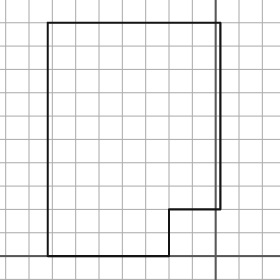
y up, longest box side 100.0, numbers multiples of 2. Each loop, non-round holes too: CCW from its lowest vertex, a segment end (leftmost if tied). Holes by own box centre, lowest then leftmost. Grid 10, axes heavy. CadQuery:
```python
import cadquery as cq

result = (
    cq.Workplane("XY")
    .moveTo(-72.0, 0.0)
    .lineTo(-20.0, 0.0)
    .lineTo(-20.0, 20.0)
    .lineTo(2.0, 20.0)
    .lineTo(2.0, 100.0)
    .lineTo(-72.0, 100.0)
    .close()
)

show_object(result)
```